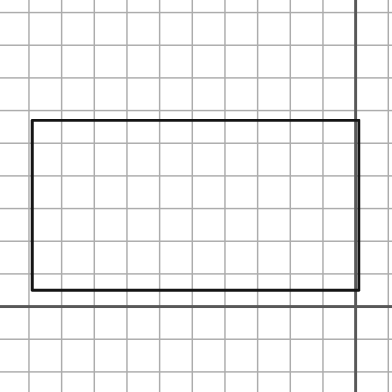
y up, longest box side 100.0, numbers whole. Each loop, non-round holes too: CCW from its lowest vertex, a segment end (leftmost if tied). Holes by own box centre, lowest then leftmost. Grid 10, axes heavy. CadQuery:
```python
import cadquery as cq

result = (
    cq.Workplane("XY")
    .moveTo(-99.0, 5.0)
    .lineTo(1.0, 5.0)
    .lineTo(1.0, 57.0)
    .lineTo(-99.0, 57.0)
    .close()
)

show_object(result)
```